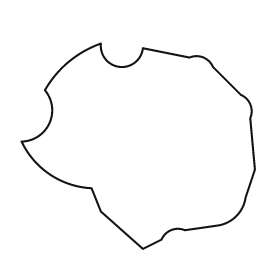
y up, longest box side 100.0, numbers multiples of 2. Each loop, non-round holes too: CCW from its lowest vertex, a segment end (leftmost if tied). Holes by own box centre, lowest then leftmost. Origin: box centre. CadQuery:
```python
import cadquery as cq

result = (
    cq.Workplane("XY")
    .moveTo(2.0, -44.0)
    .lineTo(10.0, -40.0)
    .threePointArc((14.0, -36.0), (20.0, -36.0))
    .lineTo(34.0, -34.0)
    .threePointArc((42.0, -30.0), (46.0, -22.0))
    .lineTo(50.0, -10.0)
    .lineTo(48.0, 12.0)
    .threePointArc((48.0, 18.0), (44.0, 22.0))
    .lineTo(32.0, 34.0)
    .threePointArc((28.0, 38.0), (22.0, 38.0))
    .lineTo(2.0, 42.0)
    .threePointArc((-8.0, 34.0), (-16.0, 44.0))
    .threePointArc((-30.0, 36.0), (-40.0, 24.0))
    .threePointArc((-38.0, 10.0), (-50.0, 2.0))
    .threePointArc((-38.0, -12.0), (-20.0, -18.0))
    .lineTo(-16.0, -28.0)
    .close()
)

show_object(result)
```